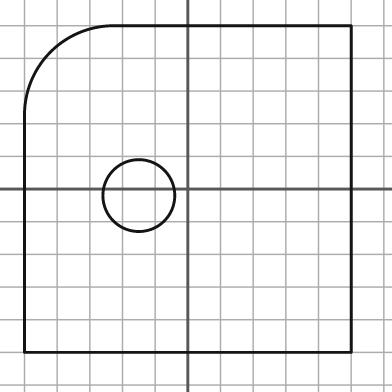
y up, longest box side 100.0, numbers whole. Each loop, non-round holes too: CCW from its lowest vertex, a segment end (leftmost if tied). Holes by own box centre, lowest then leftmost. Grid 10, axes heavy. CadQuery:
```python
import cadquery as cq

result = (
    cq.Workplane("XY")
    .moveTo(-50.0, -50.0)
    .lineTo(50.0, -50.0)
    .lineTo(50.0, 50.0)
    .lineTo(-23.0, 50.0)
    .threePointArc((-42.0, 42.0), (-50.0, 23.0))
    .close()
    .moveTo(-15.0, -2.0)
    .circle(11.0)
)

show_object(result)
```